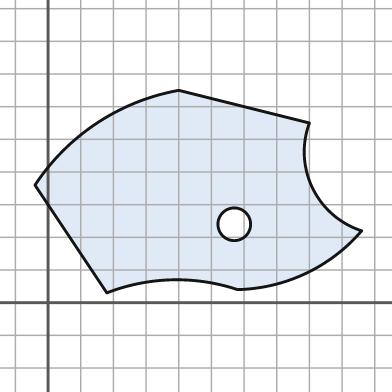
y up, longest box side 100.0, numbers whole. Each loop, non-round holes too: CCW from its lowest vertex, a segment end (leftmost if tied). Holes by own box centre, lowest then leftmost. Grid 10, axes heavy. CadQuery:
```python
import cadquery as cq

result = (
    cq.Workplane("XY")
    .moveTo(18.0, 3.0)
    .threePointArc((38.0, 7.0), (58.0, 4.0))
    .threePointArc((79.0, 9.0), (96.0, 22.0))
    .threePointArc((81.0, 35.0), (80.0, 55.0))
    .lineTo(40.0, 65.0)
    .threePointArc((15.0, 55.0), (-4.0, 36.0))
    .close()
    .moveTo(57.0, 24.0)
    .circle(5.0)
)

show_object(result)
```